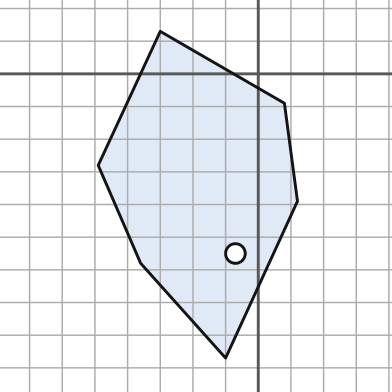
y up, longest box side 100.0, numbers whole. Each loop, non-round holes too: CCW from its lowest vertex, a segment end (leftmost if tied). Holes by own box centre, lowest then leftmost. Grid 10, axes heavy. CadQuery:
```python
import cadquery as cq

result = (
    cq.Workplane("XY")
    .moveTo(-10.0, -87.0)
    .lineTo(12.0, -39.0)
    .lineTo(8.0, -9.0)
    .lineTo(-30.0, 13.0)
    .lineTo(-49.0, -28.0)
    .lineTo(-36.0, -58.0)
    .close()
    .moveTo(-7.0, -55.0)
    .circle(3.0)
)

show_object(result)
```